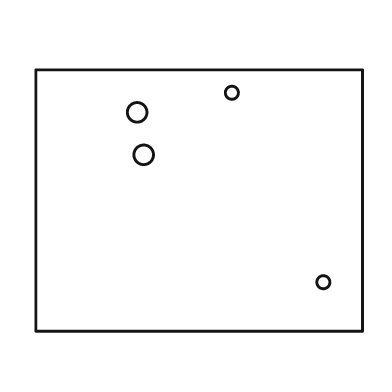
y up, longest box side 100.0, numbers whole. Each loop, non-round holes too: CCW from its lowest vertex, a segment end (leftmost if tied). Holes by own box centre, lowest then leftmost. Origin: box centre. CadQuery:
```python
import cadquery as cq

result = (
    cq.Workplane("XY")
    .moveTo(-50.0, -40.0)
    .lineTo(50.0, -40.0)
    .lineTo(50.0, 40.0)
    .lineTo(-50.0, 40.0)
    .close()
    .moveTo(38.0, -25.0)
    .circle(2.0)
    .moveTo(-17.0, 14.0)
    .circle(3.0)
    .moveTo(-19.0, 27.0)
    .circle(3.0)
    .moveTo(10.0, 33.0)
    .circle(2.0)
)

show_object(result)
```